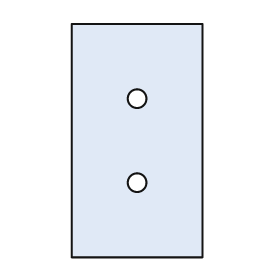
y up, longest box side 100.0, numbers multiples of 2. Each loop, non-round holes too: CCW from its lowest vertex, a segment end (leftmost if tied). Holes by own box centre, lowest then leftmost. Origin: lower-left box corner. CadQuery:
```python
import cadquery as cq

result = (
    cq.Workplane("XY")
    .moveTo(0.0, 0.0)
    .lineTo(56.0, 0.0)
    .lineTo(56.0, 100.0)
    .lineTo(0.0, 100.0)
    .close()
    .moveTo(28.0, 32.0)
    .circle(4.0)
    .moveTo(28.0, 68.0)
    .circle(4.0)
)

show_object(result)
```